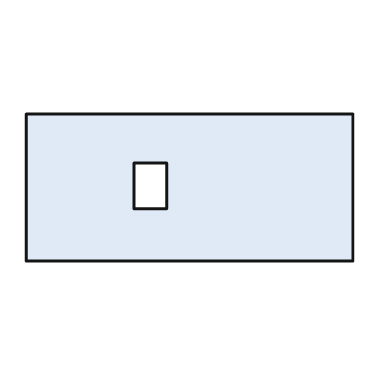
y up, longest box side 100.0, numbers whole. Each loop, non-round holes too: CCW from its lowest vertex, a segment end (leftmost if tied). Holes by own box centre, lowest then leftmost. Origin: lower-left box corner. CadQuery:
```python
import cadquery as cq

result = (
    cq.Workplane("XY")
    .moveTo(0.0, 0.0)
    .lineTo(100.0, 0.0)
    .lineTo(100.0, 45.0)
    .lineTo(0.0, 45.0)
    .close()
    .moveTo(33.0, 16.0)
    .lineTo(43.0, 16.0)
    .lineTo(43.0, 30.0)
    .lineTo(33.0, 30.0)
    .close()
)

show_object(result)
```